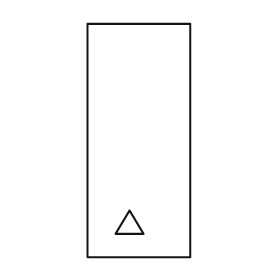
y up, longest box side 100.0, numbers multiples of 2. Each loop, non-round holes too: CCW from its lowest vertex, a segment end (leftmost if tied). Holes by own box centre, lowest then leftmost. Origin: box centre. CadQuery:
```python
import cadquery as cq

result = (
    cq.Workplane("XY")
    .moveTo(-22.0, -50.0)
    .lineTo(22.0, -50.0)
    .lineTo(22.0, 50.0)
    .lineTo(-22.0, 50.0)
    .close()
    .moveTo(-10.0, -40.0)
    .lineTo(2.0, -40.0)
    .lineTo(-4.0, -30.0)
    .close()
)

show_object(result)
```